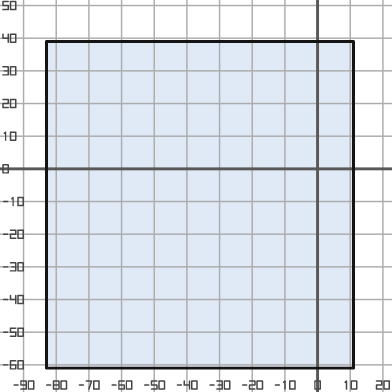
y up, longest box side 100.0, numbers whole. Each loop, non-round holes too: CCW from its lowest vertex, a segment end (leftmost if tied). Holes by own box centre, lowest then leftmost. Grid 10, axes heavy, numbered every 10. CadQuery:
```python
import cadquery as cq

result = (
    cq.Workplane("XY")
    .moveTo(-83.0, -61.0)
    .lineTo(11.0, -61.0)
    .lineTo(11.0, 39.0)
    .lineTo(-83.0, 39.0)
    .close()
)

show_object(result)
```